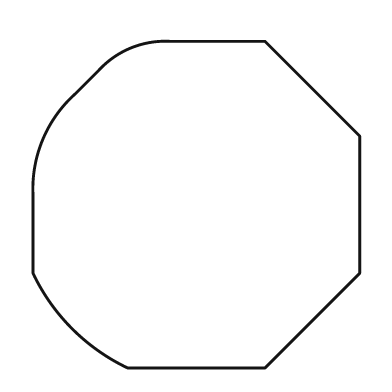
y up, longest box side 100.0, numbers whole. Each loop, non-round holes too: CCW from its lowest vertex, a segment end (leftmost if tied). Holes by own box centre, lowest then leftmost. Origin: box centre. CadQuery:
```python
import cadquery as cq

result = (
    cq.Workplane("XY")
    .moveTo(-21.0, -50.0)
    .lineTo(21.0, -50.0)
    .lineTo(50.0, -21.0)
    .lineTo(50.0, 21.0)
    .lineTo(21.0, 50.0)
    .lineTo(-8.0, 50.0)
    .threePointArc((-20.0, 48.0), (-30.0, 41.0))
    .lineTo(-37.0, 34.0)
    .threePointArc((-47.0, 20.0), (-50.0, 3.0))
    .lineTo(-50.0, -21.0)
    .threePointArc((-38.0, -38.0), (-21.0, -50.0))
    .close()
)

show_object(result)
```